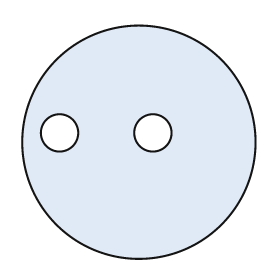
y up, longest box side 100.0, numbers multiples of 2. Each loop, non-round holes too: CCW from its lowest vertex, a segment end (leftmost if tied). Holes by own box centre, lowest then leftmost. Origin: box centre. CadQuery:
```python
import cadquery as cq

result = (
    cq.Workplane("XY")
    .moveTo(0.0, 0.0)
    .circle(50.0)
    .moveTo(-34.0, 4.0)
    .circle(8.0)
    .moveTo(6.0, 4.0)
    .circle(8.0)
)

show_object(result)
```